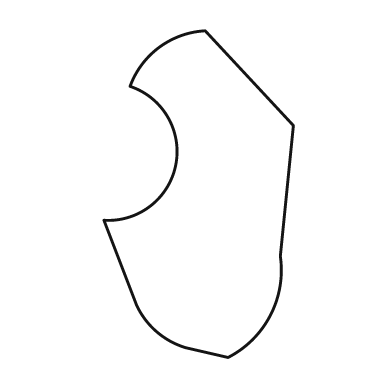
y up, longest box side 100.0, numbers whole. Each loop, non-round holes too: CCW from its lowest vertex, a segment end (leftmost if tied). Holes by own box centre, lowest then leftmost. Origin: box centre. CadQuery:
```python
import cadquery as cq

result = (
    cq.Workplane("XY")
    .moveTo(9.0, -50.0)
    .threePointArc((22.0, -37.0), (25.0, -19.0))
    .lineTo(29.0, 21.0)
    .lineTo(2.0, 50.0)
    .threePointArc((-12.0, 45.0), (-21.0, 33.0))
    .threePointArc((-7.0, 9.0), (-29.0, -8.0))
    .lineTo(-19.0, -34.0)
    .threePointArc((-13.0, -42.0), (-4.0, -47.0))
    .close()
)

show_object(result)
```